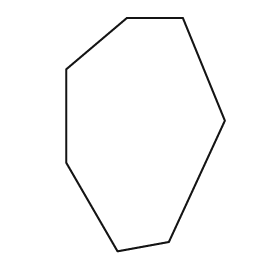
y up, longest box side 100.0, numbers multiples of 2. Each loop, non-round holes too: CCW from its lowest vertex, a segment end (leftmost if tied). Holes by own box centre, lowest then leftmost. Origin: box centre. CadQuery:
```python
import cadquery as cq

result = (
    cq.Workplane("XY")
    .moveTo(-12.0, -50.0)
    .lineTo(10.0, -46.0)
    .lineTo(34.0, 6.0)
    .lineTo(16.0, 50.0)
    .lineTo(-8.0, 50.0)
    .lineTo(-34.0, 28.0)
    .lineTo(-34.0, -12.0)
    .close()
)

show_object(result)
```